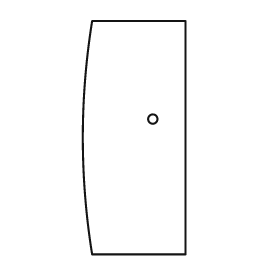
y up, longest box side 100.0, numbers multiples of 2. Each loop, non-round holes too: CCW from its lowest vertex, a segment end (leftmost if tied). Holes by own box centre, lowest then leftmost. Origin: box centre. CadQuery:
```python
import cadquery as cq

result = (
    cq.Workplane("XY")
    .moveTo(-18.0, -50.0)
    .lineTo(22.0, -50.0)
    .lineTo(22.0, 50.0)
    .lineTo(-18.0, 50.0)
    .threePointArc((-22.0, 0.0), (-18.0, -50.0))
    .close()
    .moveTo(8.0, 8.0)
    .circle(2.0)
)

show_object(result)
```